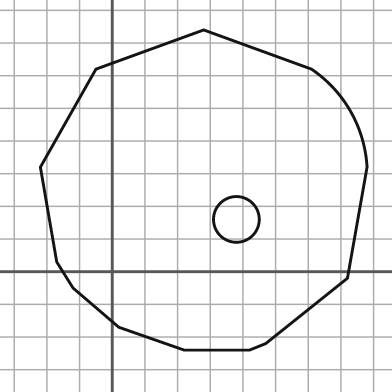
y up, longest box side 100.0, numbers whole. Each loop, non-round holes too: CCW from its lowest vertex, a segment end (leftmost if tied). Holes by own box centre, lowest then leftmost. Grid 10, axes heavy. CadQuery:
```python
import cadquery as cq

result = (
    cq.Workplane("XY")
    .moveTo(22.0, -24.0)
    .lineTo(42.0, -24.0)
    .lineTo(47.0, -22.0)
    .lineTo(72.0, -2.0)
    .lineTo(78.0, 32.0)
    .threePointArc((73.0, 49.0), (61.0, 62.0))
    .lineTo(28.0, 74.0)
    .lineTo(-5.0, 62.0)
    .lineTo(-22.0, 32.0)
    .lineTo(-17.0, 3.0)
    .lineTo(-12.0, -5.0)
    .lineTo(2.0, -17.0)
    .close()
    .moveTo(38.0, 16.0)
    .circle(7.0)
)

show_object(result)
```